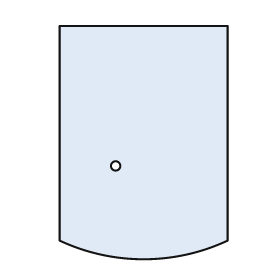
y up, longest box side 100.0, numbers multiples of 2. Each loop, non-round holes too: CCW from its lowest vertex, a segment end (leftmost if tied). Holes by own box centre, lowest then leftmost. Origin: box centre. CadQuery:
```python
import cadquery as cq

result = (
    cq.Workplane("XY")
    .moveTo(-36.0, -42.0)
    .threePointArc((0.0, -50.0), (36.0, -42.0))
    .lineTo(36.0, 50.0)
    .lineTo(-36.0, 50.0)
    .close()
    .moveTo(-12.0, -10.0)
    .circle(2.0)
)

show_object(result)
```